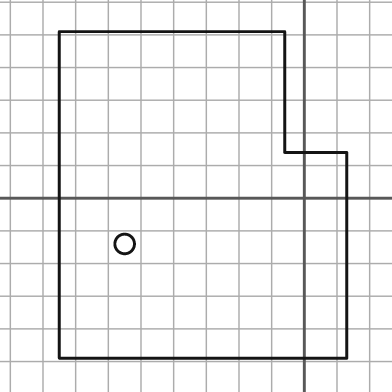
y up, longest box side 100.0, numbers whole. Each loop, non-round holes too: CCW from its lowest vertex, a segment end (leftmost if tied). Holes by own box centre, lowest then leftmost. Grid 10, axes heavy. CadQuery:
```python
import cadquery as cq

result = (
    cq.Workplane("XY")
    .moveTo(-75.0, -49.0)
    .lineTo(13.0, -49.0)
    .lineTo(13.0, 14.0)
    .lineTo(-6.0, 14.0)
    .lineTo(-6.0, 51.0)
    .lineTo(-75.0, 51.0)
    .close()
    .moveTo(-55.0, -14.0)
    .circle(3.0)
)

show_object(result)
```